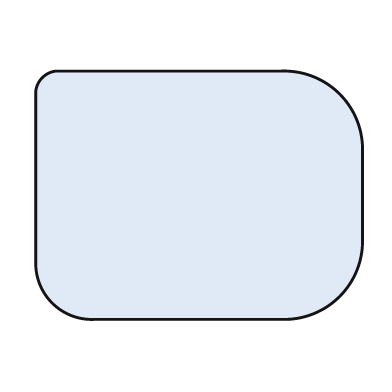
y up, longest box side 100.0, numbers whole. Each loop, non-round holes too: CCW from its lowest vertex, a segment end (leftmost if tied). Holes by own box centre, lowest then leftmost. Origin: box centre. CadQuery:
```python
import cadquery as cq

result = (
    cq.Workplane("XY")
    .moveTo(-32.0, -38.0)
    .lineTo(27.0, -38.0)
    .threePointArc((43.0, -31.0), (50.0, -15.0))
    .lineTo(50.0, 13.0)
    .threePointArc((43.0, 31.0), (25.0, 38.0))
    .lineTo(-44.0, 38.0)
    .threePointArc((-48.0, 36.0), (-50.0, 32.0))
    .lineTo(-50.0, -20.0)
    .threePointArc((-45.0, -33.0), (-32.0, -38.0))
    .close()
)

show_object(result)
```